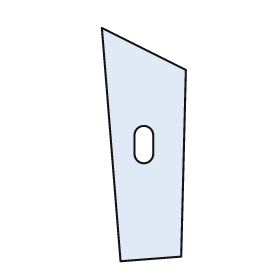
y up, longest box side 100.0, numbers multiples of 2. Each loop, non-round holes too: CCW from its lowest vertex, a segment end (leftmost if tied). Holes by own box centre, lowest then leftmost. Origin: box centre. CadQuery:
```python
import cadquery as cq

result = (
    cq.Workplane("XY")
    .moveTo(-10.0, -50.0)
    .lineTo(16.0, -48.0)
    .lineTo(18.0, 32.0)
    .lineTo(-18.0, 50.0)
    .close()
    .moveTo(-4.0, -4.0)
    .threePointArc((0.0, -8.0), (4.0, -4.0))
    .lineTo(4.0, 4.0)
    .threePointArc((0.0, 8.0), (-4.0, 4.0))
    .close()
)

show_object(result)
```